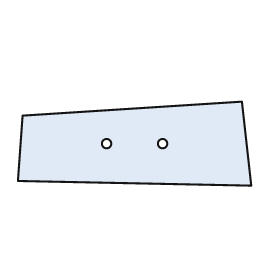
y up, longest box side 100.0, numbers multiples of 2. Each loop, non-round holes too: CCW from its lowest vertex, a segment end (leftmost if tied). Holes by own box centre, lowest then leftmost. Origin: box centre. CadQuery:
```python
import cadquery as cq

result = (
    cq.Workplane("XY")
    .moveTo(50.0, -18.0)
    .lineTo(46.0, 18.0)
    .lineTo(-48.0, 12.0)
    .lineTo(-50.0, -16.0)
    .close()
    .moveTo(-12.0, 0.0)
    .circle(2.0)
    .moveTo(12.0, 0.0)
    .circle(2.0)
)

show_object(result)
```